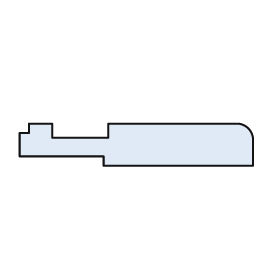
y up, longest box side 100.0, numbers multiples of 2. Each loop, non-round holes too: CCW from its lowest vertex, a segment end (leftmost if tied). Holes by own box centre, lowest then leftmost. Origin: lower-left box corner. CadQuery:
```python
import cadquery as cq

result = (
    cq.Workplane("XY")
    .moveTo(36.0, 0.0)
    .lineTo(100.0, 0.0)
    .lineTo(100.0, 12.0)
    .threePointArc((98.0, 16.0), (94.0, 18.0))
    .lineTo(38.0, 18.0)
    .lineTo(38.0, 12.0)
    .lineTo(14.0, 12.0)
    .lineTo(14.0, 18.0)
    .lineTo(4.0, 18.0)
    .lineTo(4.0, 14.0)
    .lineTo(0.0, 14.0)
    .lineTo(0.0, 4.0)
    .lineTo(36.0, 4.0)
    .close()
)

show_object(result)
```